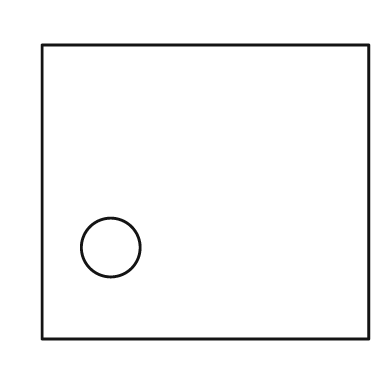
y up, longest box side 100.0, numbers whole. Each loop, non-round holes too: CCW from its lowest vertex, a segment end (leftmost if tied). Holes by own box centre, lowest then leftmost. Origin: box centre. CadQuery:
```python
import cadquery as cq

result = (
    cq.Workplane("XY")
    .moveTo(-50.0, -45.0)
    .lineTo(50.0, -45.0)
    .lineTo(50.0, 45.0)
    .lineTo(-50.0, 45.0)
    .close()
    .moveTo(-29.0, -17.0)
    .circle(9.0)
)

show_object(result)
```